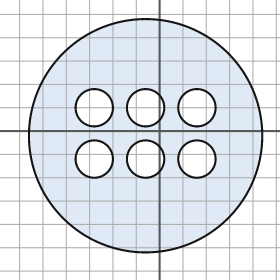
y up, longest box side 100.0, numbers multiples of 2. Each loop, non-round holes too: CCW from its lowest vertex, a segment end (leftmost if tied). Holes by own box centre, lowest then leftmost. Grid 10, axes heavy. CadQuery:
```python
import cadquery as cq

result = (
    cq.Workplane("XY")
    .moveTo(-6.0, -2.0)
    .circle(50.0)
    .moveTo(-28.0, -12.0)
    .circle(8.0)
    .moveTo(-6.0, -12.0)
    .circle(8.0)
    .moveTo(16.0, -12.0)
    .circle(8.0)
    .moveTo(-28.0, 10.0)
    .circle(8.0)
    .moveTo(-6.0, 10.0)
    .circle(8.0)
    .moveTo(16.0, 10.0)
    .circle(8.0)
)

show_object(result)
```